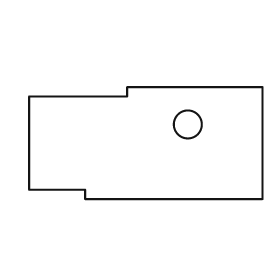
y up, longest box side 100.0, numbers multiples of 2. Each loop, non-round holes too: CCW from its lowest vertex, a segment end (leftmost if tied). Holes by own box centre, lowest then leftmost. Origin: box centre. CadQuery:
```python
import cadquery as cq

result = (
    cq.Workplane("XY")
    .moveTo(-26.0, -24.0)
    .lineTo(50.0, -24.0)
    .lineTo(50.0, 24.0)
    .lineTo(-8.0, 24.0)
    .lineTo(-8.0, 20.0)
    .lineTo(-50.0, 20.0)
    .lineTo(-50.0, -20.0)
    .lineTo(-26.0, -20.0)
    .close()
    .moveTo(18.0, 8.0)
    .circle(6.0)
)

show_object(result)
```